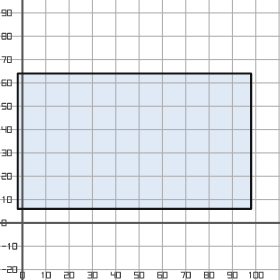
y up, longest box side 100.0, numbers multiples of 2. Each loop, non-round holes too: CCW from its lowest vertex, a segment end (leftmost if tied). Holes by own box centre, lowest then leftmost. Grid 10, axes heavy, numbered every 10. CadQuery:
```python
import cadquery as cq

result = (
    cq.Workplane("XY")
    .moveTo(-2.0, 6.0)
    .lineTo(98.0, 6.0)
    .lineTo(98.0, 64.0)
    .lineTo(-2.0, 64.0)
    .close()
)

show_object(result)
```